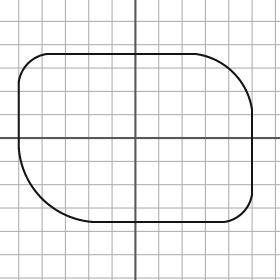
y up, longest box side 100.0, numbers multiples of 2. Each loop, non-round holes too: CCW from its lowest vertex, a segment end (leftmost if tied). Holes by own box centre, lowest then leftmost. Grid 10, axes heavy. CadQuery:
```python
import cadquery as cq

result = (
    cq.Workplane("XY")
    .moveTo(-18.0, -36.0)
    .lineTo(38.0, -36.0)
    .threePointArc((46.0, -32.0), (50.0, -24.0))
    .lineTo(50.0, 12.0)
    .threePointArc((42.0, 28.0), (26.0, 36.0))
    .lineTo(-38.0, 36.0)
    .threePointArc((-46.0, 32.0), (-50.0, 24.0))
    .lineTo(-50.0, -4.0)
    .threePointArc((-40.0, -26.0), (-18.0, -36.0))
    .close()
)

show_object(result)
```